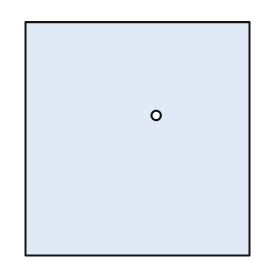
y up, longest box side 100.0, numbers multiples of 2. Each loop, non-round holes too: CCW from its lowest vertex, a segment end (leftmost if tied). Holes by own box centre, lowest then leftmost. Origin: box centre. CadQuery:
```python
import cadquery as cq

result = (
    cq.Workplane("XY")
    .moveTo(-48.0, -50.0)
    .lineTo(48.0, -50.0)
    .lineTo(48.0, 50.0)
    .lineTo(-48.0, 50.0)
    .close()
    .moveTo(8.0, 10.0)
    .circle(2.0)
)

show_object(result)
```